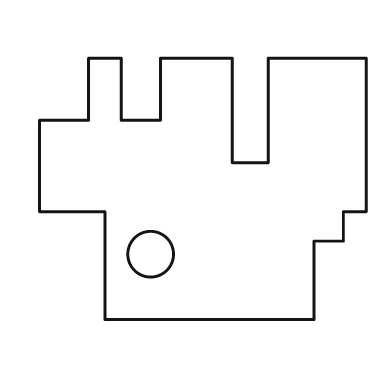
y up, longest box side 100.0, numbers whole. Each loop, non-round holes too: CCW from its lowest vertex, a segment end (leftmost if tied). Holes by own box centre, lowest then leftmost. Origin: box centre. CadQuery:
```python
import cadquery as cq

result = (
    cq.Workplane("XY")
    .moveTo(-30.0, -40.0)
    .lineTo(34.0, -40.0)
    .lineTo(34.0, -16.0)
    .lineTo(43.0, -16.0)
    .lineTo(43.0, -7.0)
    .lineTo(50.0, -7.0)
    .lineTo(50.0, 40.0)
    .lineTo(20.0, 40.0)
    .lineTo(20.0, 8.0)
    .lineTo(9.0, 8.0)
    .lineTo(9.0, 40.0)
    .lineTo(-13.0, 40.0)
    .lineTo(-13.0, 21.0)
    .lineTo(-25.0, 21.0)
    .lineTo(-25.0, 40.0)
    .lineTo(-35.0, 40.0)
    .lineTo(-35.0, 21.0)
    .lineTo(-50.0, 21.0)
    .lineTo(-50.0, -7.0)
    .lineTo(-30.0, -7.0)
    .close()
    .moveTo(-16.0, -20.0)
    .circle(7.0)
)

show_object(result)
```